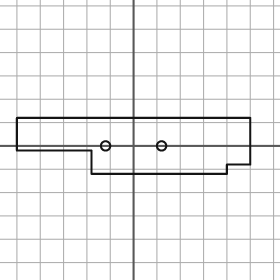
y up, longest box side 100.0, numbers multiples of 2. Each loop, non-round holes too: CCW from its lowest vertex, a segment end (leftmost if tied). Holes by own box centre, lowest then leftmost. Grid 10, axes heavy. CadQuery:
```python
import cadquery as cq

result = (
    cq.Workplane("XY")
    .moveTo(-18.0, -12.0)
    .lineTo(40.0, -12.0)
    .lineTo(40.0, -8.0)
    .lineTo(50.0, -8.0)
    .lineTo(50.0, 12.0)
    .lineTo(-50.0, 12.0)
    .lineTo(-50.0, -2.0)
    .lineTo(-18.0, -2.0)
    .close()
    .moveTo(-12.0, 0.0)
    .circle(2.0)
    .moveTo(12.0, 0.0)
    .circle(2.0)
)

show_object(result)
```